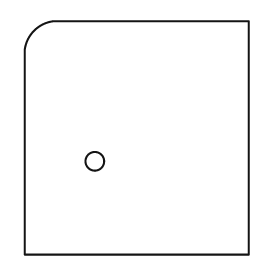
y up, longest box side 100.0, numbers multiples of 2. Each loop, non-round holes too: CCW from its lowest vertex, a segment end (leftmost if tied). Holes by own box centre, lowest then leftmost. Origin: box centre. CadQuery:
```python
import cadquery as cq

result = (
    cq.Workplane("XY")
    .moveTo(-48.0, -50.0)
    .lineTo(48.0, -50.0)
    .lineTo(48.0, 50.0)
    .lineTo(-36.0, 50.0)
    .threePointArc((-44.0, 46.0), (-48.0, 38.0))
    .close()
    .moveTo(-18.0, -10.0)
    .circle(4.0)
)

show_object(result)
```